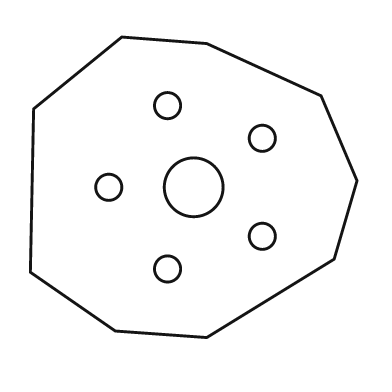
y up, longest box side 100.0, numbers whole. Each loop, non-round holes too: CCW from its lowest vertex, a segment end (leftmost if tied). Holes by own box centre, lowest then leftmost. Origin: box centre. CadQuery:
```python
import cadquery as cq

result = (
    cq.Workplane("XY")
    .moveTo(4.0, -46.0)
    .lineTo(43.0, -22.0)
    .lineTo(50.0, 2.0)
    .lineTo(39.0, 28.0)
    .lineTo(4.0, 44.0)
    .lineTo(-22.0, 46.0)
    .lineTo(-49.0, 24.0)
    .lineTo(-50.0, -26.0)
    .lineTo(-24.0, -44.0)
    .close()
    .moveTo(-8.0, -25.0)
    .circle(4.0)
    .moveTo(21.0, -15.0)
    .circle(4.0)
    .moveTo(-26.0, 0.0)
    .circle(4.0)
    .moveTo(0.0, 0.0)
    .circle(9.0)
    .moveTo(21.0, 15.0)
    .circle(4.0)
    .moveTo(-8.0, 25.0)
    .circle(4.0)
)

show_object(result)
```